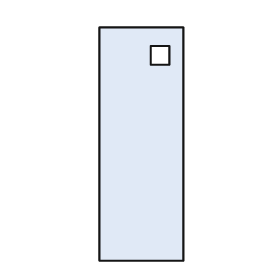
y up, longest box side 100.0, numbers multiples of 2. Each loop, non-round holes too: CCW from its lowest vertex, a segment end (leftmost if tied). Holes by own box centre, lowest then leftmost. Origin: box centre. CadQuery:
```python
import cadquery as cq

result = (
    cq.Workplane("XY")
    .moveTo(-18.0, -50.0)
    .lineTo(18.0, -50.0)
    .lineTo(18.0, 50.0)
    .lineTo(-18.0, 50.0)
    .close()
    .moveTo(4.0, 34.0)
    .lineTo(12.0, 34.0)
    .lineTo(12.0, 42.0)
    .lineTo(4.0, 42.0)
    .close()
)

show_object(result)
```